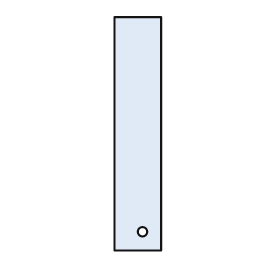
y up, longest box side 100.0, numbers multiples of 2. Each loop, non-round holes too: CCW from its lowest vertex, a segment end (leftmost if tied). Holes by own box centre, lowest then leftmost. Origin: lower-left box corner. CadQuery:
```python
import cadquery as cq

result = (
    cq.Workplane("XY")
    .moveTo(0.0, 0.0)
    .lineTo(20.0, 0.0)
    .lineTo(20.0, 100.0)
    .lineTo(0.0, 100.0)
    .close()
    .moveTo(12.0, 8.0)
    .circle(2.0)
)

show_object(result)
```